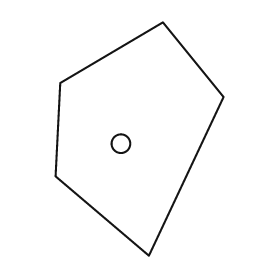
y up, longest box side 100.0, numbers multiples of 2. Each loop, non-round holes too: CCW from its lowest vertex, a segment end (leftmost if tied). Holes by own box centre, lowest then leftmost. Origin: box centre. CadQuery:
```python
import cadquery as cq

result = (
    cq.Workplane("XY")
    .moveTo(4.0, -50.0)
    .lineTo(36.0, 18.0)
    .lineTo(10.0, 50.0)
    .lineTo(-34.0, 24.0)
    .lineTo(-36.0, -16.0)
    .close()
    .moveTo(-8.0, -2.0)
    .circle(4.0)
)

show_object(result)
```